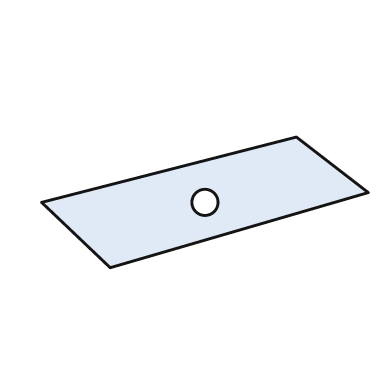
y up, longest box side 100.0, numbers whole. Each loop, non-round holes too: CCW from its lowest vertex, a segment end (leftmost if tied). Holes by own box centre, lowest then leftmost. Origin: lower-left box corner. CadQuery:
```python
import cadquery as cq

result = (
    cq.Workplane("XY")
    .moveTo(21.0, 0.0)
    .lineTo(100.0, 23.0)
    .lineTo(78.0, 40.0)
    .lineTo(0.0, 20.0)
    .close()
    .moveTo(50.0, 20.0)
    .circle(4.0)
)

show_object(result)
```